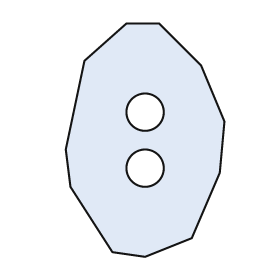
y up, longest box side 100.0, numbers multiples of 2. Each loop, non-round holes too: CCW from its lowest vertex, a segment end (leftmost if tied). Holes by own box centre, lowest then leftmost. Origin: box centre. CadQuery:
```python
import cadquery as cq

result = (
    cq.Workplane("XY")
    .moveTo(0.0, -50.0)
    .lineTo(20.0, -42.0)
    .lineTo(32.0, -14.0)
    .lineTo(34.0, 8.0)
    .lineTo(24.0, 32.0)
    .lineTo(6.0, 50.0)
    .lineTo(-8.0, 50.0)
    .lineTo(-26.0, 34.0)
    .lineTo(-34.0, -4.0)
    .lineTo(-32.0, -20.0)
    .lineTo(-14.0, -48.0)
    .close()
    .moveTo(0.0, -12.0)
    .circle(8.0)
    .moveTo(0.0, 12.0)
    .circle(8.0)
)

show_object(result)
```